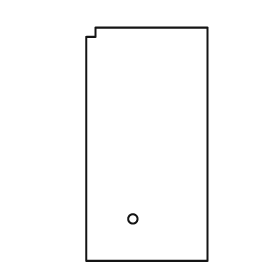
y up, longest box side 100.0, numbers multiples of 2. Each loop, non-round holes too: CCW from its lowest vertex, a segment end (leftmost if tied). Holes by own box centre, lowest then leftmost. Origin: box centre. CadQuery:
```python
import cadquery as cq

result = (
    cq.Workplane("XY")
    .moveTo(-26.0, -50.0)
    .lineTo(26.0, -50.0)
    .lineTo(26.0, 50.0)
    .lineTo(-22.0, 50.0)
    .lineTo(-22.0, 46.0)
    .lineTo(-26.0, 46.0)
    .close()
    .moveTo(-6.0, -32.0)
    .circle(2.0)
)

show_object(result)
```